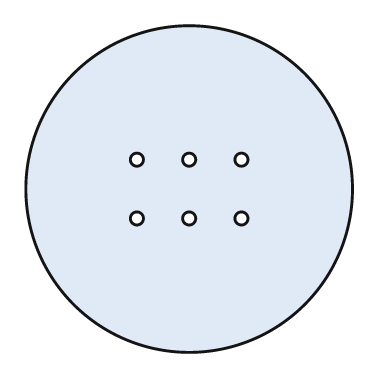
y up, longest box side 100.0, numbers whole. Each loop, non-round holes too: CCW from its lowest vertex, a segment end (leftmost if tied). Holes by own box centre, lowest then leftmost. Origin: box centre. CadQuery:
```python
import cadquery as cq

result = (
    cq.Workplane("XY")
    .moveTo(0.0, 0.0)
    .circle(50.0)
    .moveTo(-16.0, -9.0)
    .circle(2.0)
    .moveTo(0.0, -9.0)
    .circle(2.0)
    .moveTo(16.0, -9.0)
    .circle(2.0)
    .moveTo(-16.0, 9.0)
    .circle(2.0)
    .moveTo(0.0, 9.0)
    .circle(2.0)
    .moveTo(16.0, 9.0)
    .circle(2.0)
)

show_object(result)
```